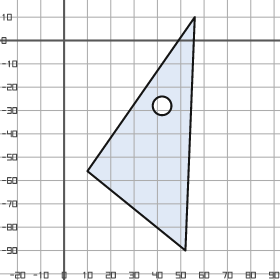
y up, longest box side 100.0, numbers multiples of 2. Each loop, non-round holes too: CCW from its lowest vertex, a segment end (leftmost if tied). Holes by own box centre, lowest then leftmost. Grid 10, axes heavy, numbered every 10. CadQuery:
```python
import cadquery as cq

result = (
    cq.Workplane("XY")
    .moveTo(52.0, -90.0)
    .lineTo(56.0, 10.0)
    .lineTo(10.0, -56.0)
    .close()
    .moveTo(42.0, -28.0)
    .circle(4.0)
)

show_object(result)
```